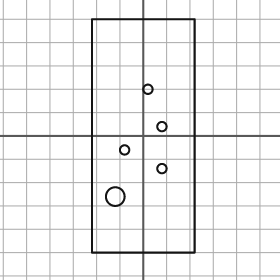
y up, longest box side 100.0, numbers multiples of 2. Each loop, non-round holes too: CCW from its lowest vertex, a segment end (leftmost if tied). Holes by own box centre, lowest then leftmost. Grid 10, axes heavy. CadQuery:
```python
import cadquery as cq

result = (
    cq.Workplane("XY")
    .moveTo(-22.0, -50.0)
    .lineTo(22.0, -50.0)
    .lineTo(22.0, 50.0)
    .lineTo(-22.0, 50.0)
    .close()
    .moveTo(-12.0, -26.0)
    .circle(4.0)
    .moveTo(8.0, -14.0)
    .circle(2.0)
    .moveTo(-8.0, -6.0)
    .circle(2.0)
    .moveTo(8.0, 4.0)
    .circle(2.0)
    .moveTo(2.0, 20.0)
    .circle(2.0)
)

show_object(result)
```